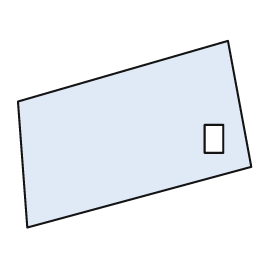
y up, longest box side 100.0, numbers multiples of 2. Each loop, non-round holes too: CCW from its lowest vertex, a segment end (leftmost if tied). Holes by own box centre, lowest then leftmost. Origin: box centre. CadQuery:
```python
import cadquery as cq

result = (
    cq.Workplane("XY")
    .moveTo(-46.0, -40.0)
    .lineTo(50.0, -14.0)
    .lineTo(40.0, 40.0)
    .lineTo(-50.0, 14.0)
    .close()
    .moveTo(30.0, -8.0)
    .lineTo(38.0, -8.0)
    .lineTo(38.0, 4.0)
    .lineTo(30.0, 4.0)
    .close()
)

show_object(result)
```